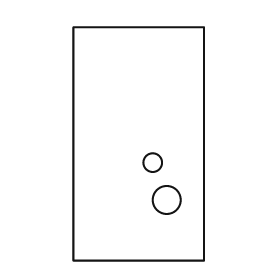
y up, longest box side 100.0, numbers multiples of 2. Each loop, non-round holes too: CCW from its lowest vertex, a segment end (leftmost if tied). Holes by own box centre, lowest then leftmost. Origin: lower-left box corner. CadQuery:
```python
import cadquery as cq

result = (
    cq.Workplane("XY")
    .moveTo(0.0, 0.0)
    .lineTo(56.0, 0.0)
    .lineTo(56.0, 100.0)
    .lineTo(0.0, 100.0)
    .close()
    .moveTo(40.0, 26.0)
    .circle(6.0)
    .moveTo(34.0, 42.0)
    .circle(4.0)
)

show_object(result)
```